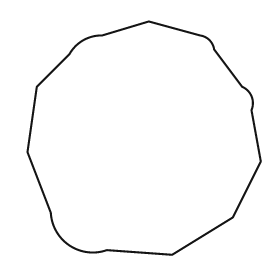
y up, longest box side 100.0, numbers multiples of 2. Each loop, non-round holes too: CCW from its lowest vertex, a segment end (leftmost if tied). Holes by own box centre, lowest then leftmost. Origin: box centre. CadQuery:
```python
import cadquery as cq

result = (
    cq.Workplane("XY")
    .moveTo(12.0, -50.0)
    .lineTo(38.0, -34.0)
    .lineTo(50.0, -10.0)
    .lineTo(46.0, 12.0)
    .threePointArc((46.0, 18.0), (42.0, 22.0))
    .lineTo(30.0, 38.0)
    .threePointArc((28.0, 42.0), (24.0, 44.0))
    .lineTo(2.0, 50.0)
    .lineTo(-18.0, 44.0)
    .threePointArc((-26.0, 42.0), (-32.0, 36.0))
    .lineTo(-46.0, 22.0)
    .lineTo(-50.0, -6.0)
    .lineTo(-40.0, -32.0)
    .threePointArc((-32.0, -46.0), (-16.0, -48.0))
    .close()
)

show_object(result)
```